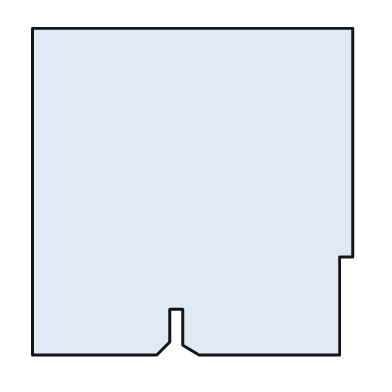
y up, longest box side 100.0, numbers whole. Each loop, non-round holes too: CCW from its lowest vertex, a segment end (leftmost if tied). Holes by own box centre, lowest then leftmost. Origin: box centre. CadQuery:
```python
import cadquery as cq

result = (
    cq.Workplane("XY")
    .moveTo(-49.0, -50.0)
    .lineTo(-11.0, -50.0)
    .lineTo(-7.0, -46.0)
    .lineTo(-7.0, -36.0)
    .lineTo(-3.0, -36.0)
    .lineTo(-3.0, -47.0)
    .lineTo(2.0, -50.0)
    .lineTo(45.0, -50.0)
    .lineTo(45.0, -20.0)
    .lineTo(49.0, -20.0)
    .lineTo(49.0, 50.0)
    .lineTo(-49.0, 50.0)
    .close()
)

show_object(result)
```